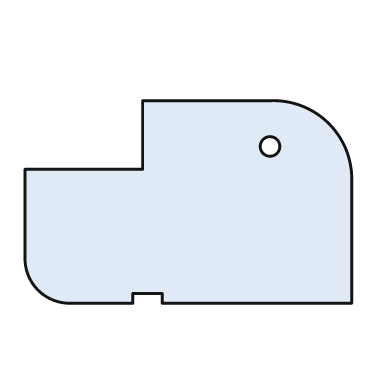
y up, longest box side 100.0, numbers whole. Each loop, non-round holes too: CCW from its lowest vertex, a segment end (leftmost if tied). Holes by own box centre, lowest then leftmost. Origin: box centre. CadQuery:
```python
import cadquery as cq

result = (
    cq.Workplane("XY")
    .moveTo(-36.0, -31.0)
    .lineTo(-17.0, -31.0)
    .lineTo(-17.0, -28.0)
    .lineTo(-8.0, -28.0)
    .lineTo(-8.0, -31.0)
    .lineTo(50.0, -31.0)
    .lineTo(50.0, 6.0)
    .threePointArc((43.0, 24.0), (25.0, 31.0))
    .lineTo(-14.0, 31.0)
    .lineTo(-14.0, 10.0)
    .lineTo(-50.0, 10.0)
    .lineTo(-50.0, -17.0)
    .threePointArc((-46.0, -27.0), (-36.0, -31.0))
    .close()
    .moveTo(25.0, 17.0)
    .circle(3.0)
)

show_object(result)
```